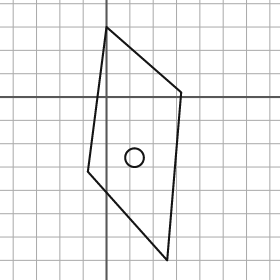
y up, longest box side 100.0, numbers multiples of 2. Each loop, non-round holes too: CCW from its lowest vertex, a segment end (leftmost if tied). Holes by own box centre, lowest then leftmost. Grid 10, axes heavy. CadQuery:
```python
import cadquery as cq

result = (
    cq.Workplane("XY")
    .moveTo(26.0, -70.0)
    .lineTo(32.0, 2.0)
    .lineTo(0.0, 30.0)
    .lineTo(-8.0, -32.0)
    .close()
    .moveTo(12.0, -26.0)
    .circle(4.0)
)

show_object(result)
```